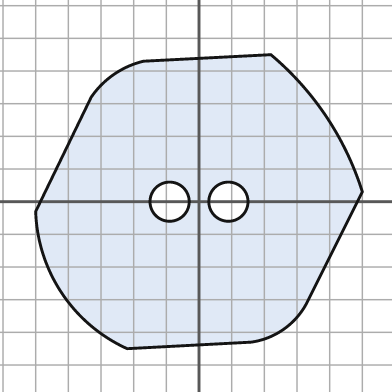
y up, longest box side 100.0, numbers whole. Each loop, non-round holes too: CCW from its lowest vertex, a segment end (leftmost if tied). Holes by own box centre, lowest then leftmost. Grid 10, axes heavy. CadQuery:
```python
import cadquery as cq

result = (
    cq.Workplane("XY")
    .moveTo(-22.0, -45.0)
    .lineTo(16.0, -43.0)
    .threePointArc((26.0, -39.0), (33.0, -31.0))
    .lineTo(50.0, 3.0)
    .threePointArc((39.0, 26.0), (22.0, 45.0))
    .lineTo(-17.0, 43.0)
    .threePointArc((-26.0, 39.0), (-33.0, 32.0))
    .lineTo(-50.0, -3.0)
    .threePointArc((-42.0, -28.0), (-22.0, -45.0))
    .close()
    .moveTo(-9.0, 0.0)
    .circle(6.0)
    .moveTo(9.0, 0.0)
    .circle(6.0)
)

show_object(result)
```